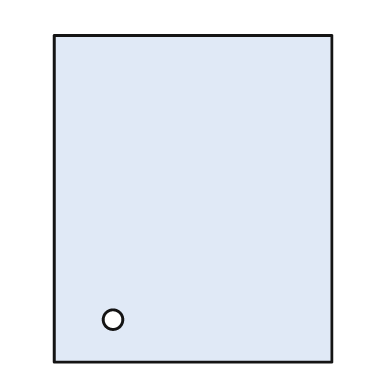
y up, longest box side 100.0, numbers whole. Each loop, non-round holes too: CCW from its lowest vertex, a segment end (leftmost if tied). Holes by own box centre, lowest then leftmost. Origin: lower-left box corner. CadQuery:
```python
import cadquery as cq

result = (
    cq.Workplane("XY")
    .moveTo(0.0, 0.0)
    .lineTo(85.0, 0.0)
    .lineTo(85.0, 100.0)
    .lineTo(0.0, 100.0)
    .close()
    .moveTo(18.0, 13.0)
    .circle(3.0)
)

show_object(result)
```